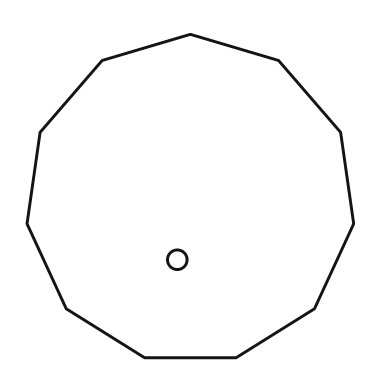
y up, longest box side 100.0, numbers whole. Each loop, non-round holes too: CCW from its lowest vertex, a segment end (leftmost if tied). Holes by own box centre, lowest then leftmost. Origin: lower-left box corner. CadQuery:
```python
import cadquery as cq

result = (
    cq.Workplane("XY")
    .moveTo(36.0, 0.0)
    .lineTo(64.0, 0.0)
    .lineTo(88.0, 15.0)
    .lineTo(100.0, 41.0)
    .lineTo(96.0, 69.0)
    .lineTo(77.0, 91.0)
    .lineTo(50.0, 99.0)
    .lineTo(23.0, 91.0)
    .lineTo(4.0, 69.0)
    .lineTo(0.0, 41.0)
    .lineTo(12.0, 15.0)
    .close()
    .moveTo(46.0, 30.0)
    .circle(3.0)
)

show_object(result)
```